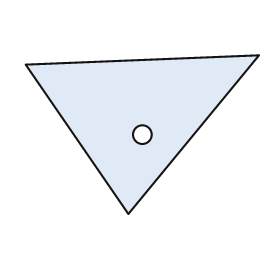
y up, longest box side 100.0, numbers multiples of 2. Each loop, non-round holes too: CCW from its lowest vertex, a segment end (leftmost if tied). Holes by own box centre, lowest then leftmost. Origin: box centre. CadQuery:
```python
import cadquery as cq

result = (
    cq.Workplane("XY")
    .moveTo(-6.0, -34.0)
    .lineTo(50.0, 34.0)
    .lineTo(-50.0, 30.0)
    .close()
    .moveTo(0.0, 0.0)
    .circle(4.0)
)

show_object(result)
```